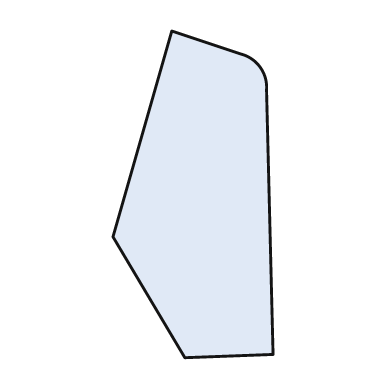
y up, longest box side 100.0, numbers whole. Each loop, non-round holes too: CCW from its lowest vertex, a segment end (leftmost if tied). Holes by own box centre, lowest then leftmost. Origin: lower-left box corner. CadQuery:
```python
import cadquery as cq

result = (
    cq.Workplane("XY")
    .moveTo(22.0, 0.0)
    .lineTo(49.0, 1.0)
    .lineTo(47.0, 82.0)
    .threePointArc((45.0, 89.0), (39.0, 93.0))
    .lineTo(18.0, 100.0)
    .lineTo(0.0, 37.0)
    .close()
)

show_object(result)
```